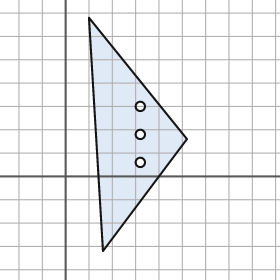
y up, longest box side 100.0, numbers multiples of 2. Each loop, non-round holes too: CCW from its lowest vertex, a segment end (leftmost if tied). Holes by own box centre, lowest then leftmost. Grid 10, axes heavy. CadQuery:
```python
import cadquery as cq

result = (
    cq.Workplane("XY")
    .moveTo(16.0, -32.0)
    .lineTo(52.0, 16.0)
    .lineTo(10.0, 68.0)
    .close()
    .moveTo(32.0, 6.0)
    .circle(2.0)
    .moveTo(32.0, 18.0)
    .circle(2.0)
    .moveTo(32.0, 30.0)
    .circle(2.0)
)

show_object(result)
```